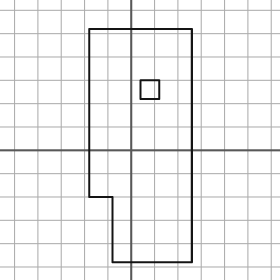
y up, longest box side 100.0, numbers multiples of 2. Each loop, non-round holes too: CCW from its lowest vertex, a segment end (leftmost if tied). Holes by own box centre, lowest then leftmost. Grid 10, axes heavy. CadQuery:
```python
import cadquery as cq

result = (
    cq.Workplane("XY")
    .moveTo(-8.0, -48.0)
    .lineTo(26.0, -48.0)
    .lineTo(26.0, 52.0)
    .lineTo(-18.0, 52.0)
    .lineTo(-18.0, -20.0)
    .lineTo(-8.0, -20.0)
    .close()
    .moveTo(4.0, 22.0)
    .lineTo(12.0, 22.0)
    .lineTo(12.0, 30.0)
    .lineTo(4.0, 30.0)
    .close()
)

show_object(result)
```